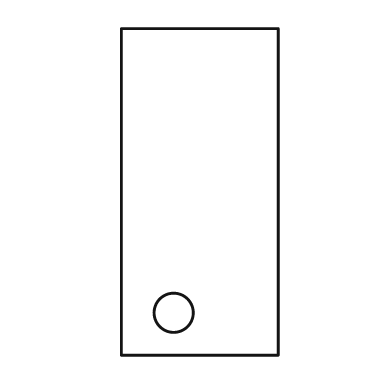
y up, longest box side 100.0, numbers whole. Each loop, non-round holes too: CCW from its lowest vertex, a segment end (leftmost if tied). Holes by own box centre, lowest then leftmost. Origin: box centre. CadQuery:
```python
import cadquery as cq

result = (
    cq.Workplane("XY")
    .moveTo(-24.0, -50.0)
    .lineTo(24.0, -50.0)
    .lineTo(24.0, 50.0)
    .lineTo(-24.0, 50.0)
    .close()
    .moveTo(-8.0, -37.0)
    .circle(6.0)
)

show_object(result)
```